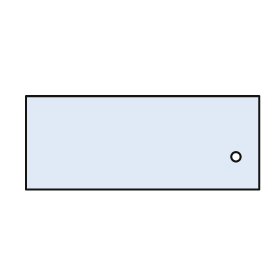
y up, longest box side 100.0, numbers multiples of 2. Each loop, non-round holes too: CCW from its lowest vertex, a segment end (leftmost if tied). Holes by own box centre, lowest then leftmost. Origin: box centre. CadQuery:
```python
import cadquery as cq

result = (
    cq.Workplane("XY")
    .moveTo(-50.0, -20.0)
    .lineTo(50.0, -20.0)
    .lineTo(50.0, 20.0)
    .lineTo(-50.0, 20.0)
    .close()
    .moveTo(40.0, -6.0)
    .circle(2.0)
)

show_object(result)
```